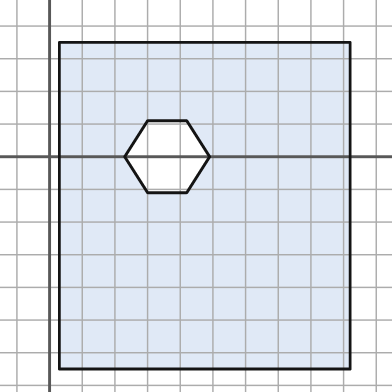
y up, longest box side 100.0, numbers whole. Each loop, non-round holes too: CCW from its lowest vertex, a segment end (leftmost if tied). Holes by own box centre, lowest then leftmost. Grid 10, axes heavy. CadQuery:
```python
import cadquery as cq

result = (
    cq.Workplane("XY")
    .moveTo(3.0, -65.0)
    .lineTo(92.0, -65.0)
    .lineTo(92.0, 35.0)
    .lineTo(3.0, 35.0)
    .close()
    .moveTo(30.0, -11.0)
    .lineTo(42.0, -11.0)
    .lineTo(49.0, 0.0)
    .lineTo(42.0, 11.0)
    .lineTo(30.0, 11.0)
    .lineTo(23.0, 0.0)
    .close()
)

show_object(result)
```